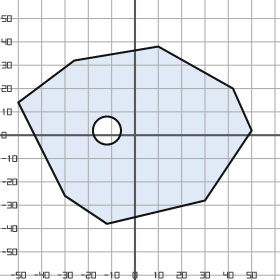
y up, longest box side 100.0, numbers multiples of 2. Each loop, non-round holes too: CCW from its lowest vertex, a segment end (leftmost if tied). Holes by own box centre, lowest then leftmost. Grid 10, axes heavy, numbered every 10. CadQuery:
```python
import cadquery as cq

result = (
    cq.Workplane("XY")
    .moveTo(-12.0, -38.0)
    .lineTo(30.0, -28.0)
    .lineTo(50.0, 2.0)
    .lineTo(42.0, 20.0)
    .lineTo(10.0, 38.0)
    .lineTo(-26.0, 32.0)
    .lineTo(-50.0, 14.0)
    .lineTo(-30.0, -26.0)
    .close()
    .moveTo(-12.0, 2.0)
    .circle(6.0)
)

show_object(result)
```